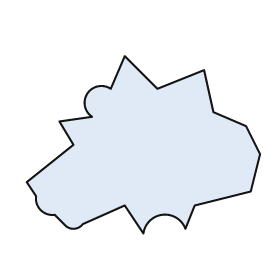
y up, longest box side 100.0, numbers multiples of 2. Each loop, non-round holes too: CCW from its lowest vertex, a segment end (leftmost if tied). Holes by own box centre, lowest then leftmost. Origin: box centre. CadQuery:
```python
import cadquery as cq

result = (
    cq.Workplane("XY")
    .moveTo(0.0, -38.0)
    .threePointArc((8.0, -30.0), (18.0, -36.0))
    .lineTo(22.0, -26.0)
    .lineTo(46.0, -20.0)
    .lineTo(50.0, -4.0)
    .lineTo(44.0, 8.0)
    .lineTo(30.0, 14.0)
    .lineTo(26.0, 32.0)
    .lineTo(6.0, 24.0)
    .lineTo(-8.0, 38.0)
    .lineTo(-14.0, 24.0)
    .threePointArc((-24.0, 22.0), (-22.0, 12.0))
    .lineTo(-36.0, 10.0)
    .lineTo(-30.0, 0.0)
    .lineTo(-50.0, -16.0)
    .lineTo(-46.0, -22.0)
    .threePointArc((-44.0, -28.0), (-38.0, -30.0))
    .lineTo(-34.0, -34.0)
    .threePointArc((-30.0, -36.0), (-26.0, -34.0))
    .lineTo(-8.0, -26.0)
    .close()
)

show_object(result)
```